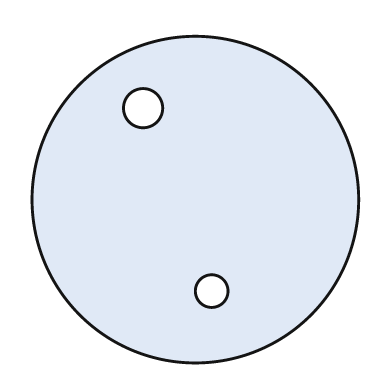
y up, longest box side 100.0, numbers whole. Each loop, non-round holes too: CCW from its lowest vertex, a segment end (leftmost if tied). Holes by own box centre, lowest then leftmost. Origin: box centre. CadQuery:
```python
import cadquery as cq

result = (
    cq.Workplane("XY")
    .moveTo(0.0, 0.0)
    .circle(50.0)
    .moveTo(5.0, -28.0)
    .circle(5.0)
    .moveTo(-16.0, 28.0)
    .circle(6.0)
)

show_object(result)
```